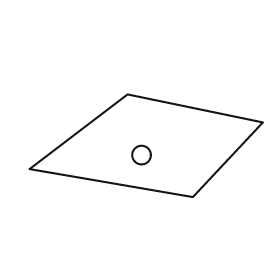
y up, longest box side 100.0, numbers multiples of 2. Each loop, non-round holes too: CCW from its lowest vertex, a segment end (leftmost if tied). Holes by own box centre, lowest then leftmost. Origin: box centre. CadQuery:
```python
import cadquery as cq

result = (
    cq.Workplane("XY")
    .moveTo(20.0, -22.0)
    .lineTo(50.0, 10.0)
    .lineTo(-8.0, 22.0)
    .lineTo(-50.0, -10.0)
    .close()
    .moveTo(-2.0, -4.0)
    .circle(4.0)
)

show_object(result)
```